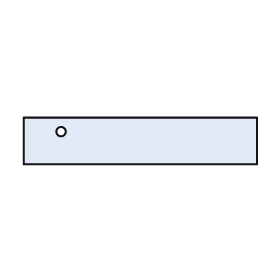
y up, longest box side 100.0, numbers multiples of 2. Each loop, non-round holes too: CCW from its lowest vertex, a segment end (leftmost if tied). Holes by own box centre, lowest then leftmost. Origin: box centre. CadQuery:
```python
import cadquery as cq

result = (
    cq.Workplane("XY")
    .moveTo(-50.0, -10.0)
    .lineTo(50.0, -10.0)
    .lineTo(50.0, 10.0)
    .lineTo(-50.0, 10.0)
    .close()
    .moveTo(-34.0, 4.0)
    .circle(2.0)
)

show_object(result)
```